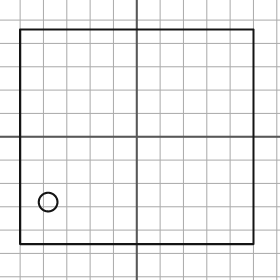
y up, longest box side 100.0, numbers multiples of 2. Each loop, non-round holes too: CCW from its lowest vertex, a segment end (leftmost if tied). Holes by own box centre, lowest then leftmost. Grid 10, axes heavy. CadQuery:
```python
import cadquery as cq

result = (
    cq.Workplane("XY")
    .moveTo(-50.0, -46.0)
    .lineTo(50.0, -46.0)
    .lineTo(50.0, 46.0)
    .lineTo(-50.0, 46.0)
    .close()
    .moveTo(-38.0, -28.0)
    .circle(4.0)
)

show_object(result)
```